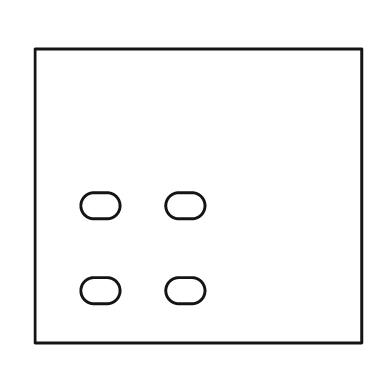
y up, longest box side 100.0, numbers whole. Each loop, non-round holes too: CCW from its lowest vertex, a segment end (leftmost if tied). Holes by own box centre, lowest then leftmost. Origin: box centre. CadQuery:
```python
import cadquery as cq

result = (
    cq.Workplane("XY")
    .moveTo(-50.0, -45.0)
    .lineTo(50.0, -45.0)
    .lineTo(50.0, 45.0)
    .lineTo(-50.0, 45.0)
    .close()
    .moveTo(-32.0, -33.0)
    .lineTo(-28.0, -33.0)
    .threePointArc((-24.0, -29.0), (-28.0, -25.0))
    .lineTo(-32.0, -25.0)
    .threePointArc((-36.0, -29.0), (-32.0, -33.0))
    .close()
    .moveTo(-6.0, -33.0)
    .lineTo(-2.0, -33.0)
    .threePointArc((2.0, -29.0), (-2.0, -25.0))
    .lineTo(-6.0, -25.0)
    .threePointArc((-10.0, -29.0), (-6.0, -33.0))
    .close()
    .moveTo(-32.0, -7.0)
    .lineTo(-28.0, -7.0)
    .threePointArc((-24.0, -3.0), (-28.0, 1.0))
    .lineTo(-32.0, 1.0)
    .threePointArc((-36.0, -3.0), (-32.0, -7.0))
    .close()
    .moveTo(-6.0, -7.0)
    .lineTo(-2.0, -7.0)
    .threePointArc((2.0, -3.0), (-2.0, 1.0))
    .lineTo(-6.0, 1.0)
    .threePointArc((-10.0, -3.0), (-6.0, -7.0))
    .close()
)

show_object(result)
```